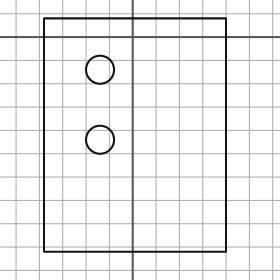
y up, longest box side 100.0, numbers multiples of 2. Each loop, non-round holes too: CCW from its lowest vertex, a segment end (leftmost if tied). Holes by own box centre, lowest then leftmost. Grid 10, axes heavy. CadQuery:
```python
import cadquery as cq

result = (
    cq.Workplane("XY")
    .moveTo(-38.0, -92.0)
    .lineTo(40.0, -92.0)
    .lineTo(40.0, 8.0)
    .lineTo(-38.0, 8.0)
    .close()
    .moveTo(-14.0, -44.0)
    .circle(6.0)
    .moveTo(-14.0, -14.0)
    .circle(6.0)
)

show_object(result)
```